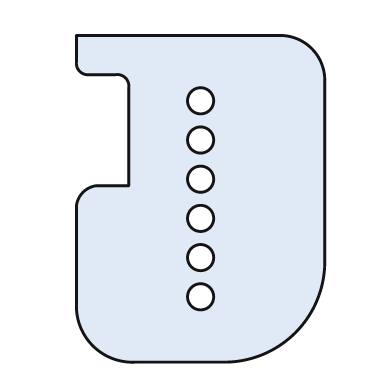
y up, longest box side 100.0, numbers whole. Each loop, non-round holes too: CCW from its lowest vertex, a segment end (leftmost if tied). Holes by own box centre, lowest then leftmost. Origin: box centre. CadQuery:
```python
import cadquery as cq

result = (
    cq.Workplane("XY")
    .moveTo(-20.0, -50.0)
    .lineTo(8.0, -50.0)
    .threePointArc((29.0, -41.0), (38.0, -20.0))
    .lineTo(38.0, 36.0)
    .threePointArc((34.0, 46.0), (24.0, 50.0))
    .lineTo(-38.0, 50.0)
    .lineTo(-38.0, 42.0)
    .threePointArc((-37.0, 39.0), (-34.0, 38.0))
    .lineTo(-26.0, 38.0)
    .threePointArc((-23.0, 37.0), (-22.0, 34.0))
    .lineTo(-22.0, 4.0)
    .lineTo(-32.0, 4.0)
    .threePointArc((-36.0, 2.0), (-38.0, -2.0))
    .lineTo(-38.0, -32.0)
    .threePointArc((-33.0, -45.0), (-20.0, -50.0))
    .close()
    .moveTo(0.0, -30.0)
    .circle(4.0)
    .moveTo(0.0, -18.0)
    .circle(4.0)
    .moveTo(0.0, -6.0)
    .circle(4.0)
    .moveTo(0.0, 6.0)
    .circle(4.0)
    .moveTo(0.0, 18.0)
    .circle(4.0)
    .moveTo(0.0, 30.0)
    .circle(4.0)
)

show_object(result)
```